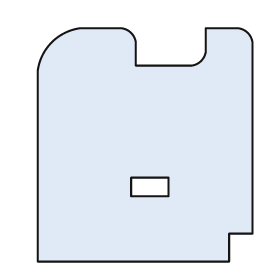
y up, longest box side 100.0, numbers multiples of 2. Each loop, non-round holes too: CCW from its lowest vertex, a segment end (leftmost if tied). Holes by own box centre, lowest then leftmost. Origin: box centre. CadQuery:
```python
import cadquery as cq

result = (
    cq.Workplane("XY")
    .moveTo(-46.0, -50.0)
    .lineTo(36.0, -50.0)
    .lineTo(36.0, -38.0)
    .lineTo(46.0, -38.0)
    .lineTo(46.0, 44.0)
    .threePointArc((44.0, 48.0), (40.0, 50.0))
    .lineTo(26.0, 50.0)
    .lineTo(26.0, 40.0)
    .threePointArc((24.0, 36.0), (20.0, 34.0))
    .lineTo(-4.0, 34.0)
    .lineTo(-4.0, 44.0)
    .threePointArc((-6.0, 48.0), (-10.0, 50.0))
    .lineTo(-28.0, 50.0)
    .threePointArc((-40.0, 44.0), (-46.0, 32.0))
    .close()
    .moveTo(-6.0, -22.0)
    .lineTo(10.0, -22.0)
    .lineTo(10.0, -14.0)
    .lineTo(-6.0, -14.0)
    .close()
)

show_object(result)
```